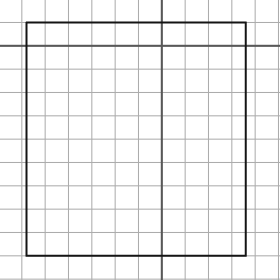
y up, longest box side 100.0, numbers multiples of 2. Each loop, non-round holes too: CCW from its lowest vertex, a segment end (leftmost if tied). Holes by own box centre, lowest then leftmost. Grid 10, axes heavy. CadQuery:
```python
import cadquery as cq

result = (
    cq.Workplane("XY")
    .moveTo(-58.0, -90.0)
    .lineTo(36.0, -90.0)
    .lineTo(36.0, 10.0)
    .lineTo(-58.0, 10.0)
    .close()
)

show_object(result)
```